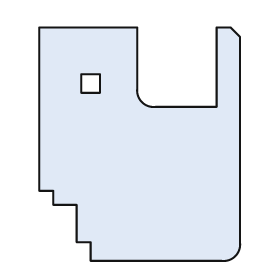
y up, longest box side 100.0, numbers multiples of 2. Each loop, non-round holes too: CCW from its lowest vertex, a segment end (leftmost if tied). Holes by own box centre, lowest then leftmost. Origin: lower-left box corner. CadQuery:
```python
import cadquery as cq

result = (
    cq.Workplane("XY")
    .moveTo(22.0, 0.0)
    .lineTo(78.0, 0.0)
    .threePointArc((84.0, 2.0), (86.0, 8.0))
    .lineTo(86.0, 96.0)
    .lineTo(82.0, 100.0)
    .lineTo(76.0, 100.0)
    .lineTo(76.0, 66.0)
    .lineTo(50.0, 66.0)
    .threePointArc((44.0, 68.0), (42.0, 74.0))
    .lineTo(42.0, 100.0)
    .lineTo(0.0, 100.0)
    .lineTo(0.0, 30.0)
    .lineTo(6.0, 30.0)
    .lineTo(6.0, 24.0)
    .lineTo(16.0, 24.0)
    .lineTo(16.0, 8.0)
    .lineTo(22.0, 8.0)
    .close()
    .moveTo(18.0, 72.0)
    .lineTo(26.0, 72.0)
    .lineTo(26.0, 80.0)
    .lineTo(18.0, 80.0)
    .close()
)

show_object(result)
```